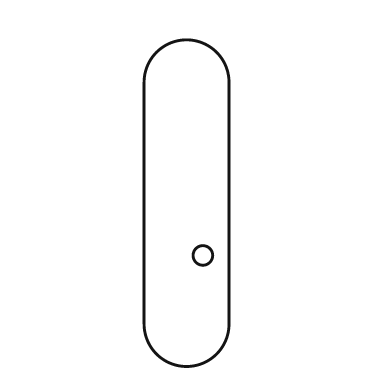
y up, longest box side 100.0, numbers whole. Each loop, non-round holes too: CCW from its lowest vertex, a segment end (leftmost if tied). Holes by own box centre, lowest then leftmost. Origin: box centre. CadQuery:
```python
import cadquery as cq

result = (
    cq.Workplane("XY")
    .moveTo(-13.0, -37.0)
    .threePointArc((0.0, -50.0), (13.0, -37.0))
    .lineTo(13.0, 37.0)
    .threePointArc((0.0, 50.0), (-13.0, 37.0))
    .close()
    .moveTo(5.0, -16.0)
    .circle(3.0)
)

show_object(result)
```